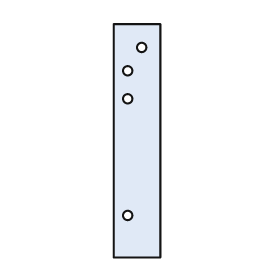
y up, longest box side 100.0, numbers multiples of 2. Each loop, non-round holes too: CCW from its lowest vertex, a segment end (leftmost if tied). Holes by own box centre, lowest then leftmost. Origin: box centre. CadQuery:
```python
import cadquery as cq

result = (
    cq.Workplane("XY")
    .moveTo(-10.0, -50.0)
    .lineTo(10.0, -50.0)
    .lineTo(10.0, 50.0)
    .lineTo(-10.0, 50.0)
    .close()
    .moveTo(-4.0, -32.0)
    .circle(2.0)
    .moveTo(-4.0, 18.0)
    .circle(2.0)
    .moveTo(-4.0, 30.0)
    .circle(2.0)
    .moveTo(2.0, 40.0)
    .circle(2.0)
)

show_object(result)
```